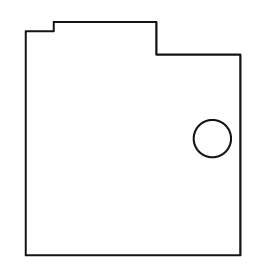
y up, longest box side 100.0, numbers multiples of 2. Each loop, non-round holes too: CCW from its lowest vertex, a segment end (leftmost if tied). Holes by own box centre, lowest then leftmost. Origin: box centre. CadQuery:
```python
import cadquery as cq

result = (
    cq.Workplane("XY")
    .moveTo(-46.0, -50.0)
    .lineTo(46.0, -50.0)
    .lineTo(46.0, 36.0)
    .lineTo(10.0, 36.0)
    .lineTo(10.0, 50.0)
    .lineTo(-34.0, 50.0)
    .lineTo(-34.0, 46.0)
    .lineTo(-46.0, 46.0)
    .close()
    .moveTo(34.0, 0.0)
    .circle(8.0)
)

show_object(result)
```